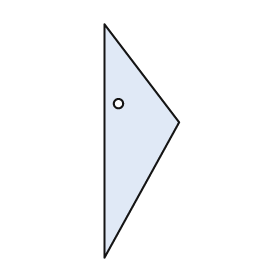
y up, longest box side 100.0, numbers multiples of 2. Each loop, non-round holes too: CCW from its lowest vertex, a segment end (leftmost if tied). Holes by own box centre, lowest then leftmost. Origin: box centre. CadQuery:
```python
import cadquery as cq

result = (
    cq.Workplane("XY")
    .moveTo(-16.0, -50.0)
    .lineTo(16.0, 8.0)
    .lineTo(-16.0, 50.0)
    .close()
    .moveTo(-10.0, 16.0)
    .circle(2.0)
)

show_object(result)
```